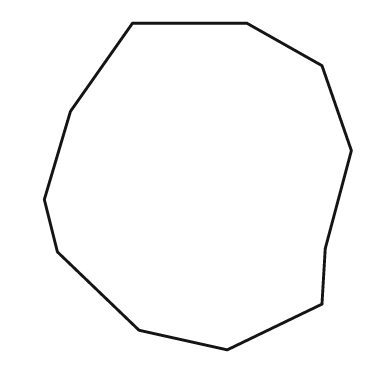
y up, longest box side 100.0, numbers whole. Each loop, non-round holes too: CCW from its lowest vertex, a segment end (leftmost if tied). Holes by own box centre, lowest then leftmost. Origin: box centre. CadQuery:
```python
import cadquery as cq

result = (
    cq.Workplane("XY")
    .moveTo(9.0, -50.0)
    .lineTo(38.0, -36.0)
    .lineTo(39.0, -19.0)
    .lineTo(47.0, 11.0)
    .lineTo(38.0, 37.0)
    .lineTo(15.0, 50.0)
    .lineTo(-20.0, 50.0)
    .lineTo(-39.0, 23.0)
    .lineTo(-47.0, -4.0)
    .lineTo(-43.0, -20.0)
    .lineTo(-18.0, -44.0)
    .close()
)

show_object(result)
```